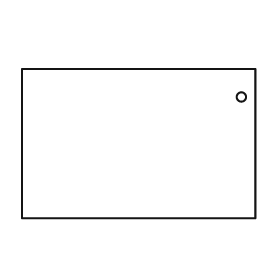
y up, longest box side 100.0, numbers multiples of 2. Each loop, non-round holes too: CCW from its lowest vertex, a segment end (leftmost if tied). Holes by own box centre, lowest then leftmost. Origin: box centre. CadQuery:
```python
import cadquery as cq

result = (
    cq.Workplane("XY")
    .moveTo(-50.0, -32.0)
    .lineTo(50.0, -32.0)
    .lineTo(50.0, 32.0)
    .lineTo(-50.0, 32.0)
    .close()
    .moveTo(44.0, 20.0)
    .circle(2.0)
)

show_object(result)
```